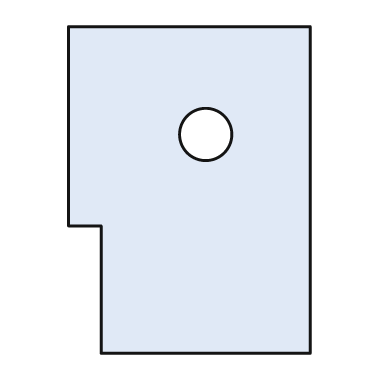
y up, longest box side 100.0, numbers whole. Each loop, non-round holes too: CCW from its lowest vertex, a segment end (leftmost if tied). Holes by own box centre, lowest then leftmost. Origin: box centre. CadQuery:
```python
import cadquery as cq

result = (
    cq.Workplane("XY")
    .moveTo(-27.0, -50.0)
    .lineTo(37.0, -50.0)
    .lineTo(37.0, 50.0)
    .lineTo(-37.0, 50.0)
    .lineTo(-37.0, -11.0)
    .lineTo(-27.0, -11.0)
    .close()
    .moveTo(5.0, 17.0)
    .circle(8.0)
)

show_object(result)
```